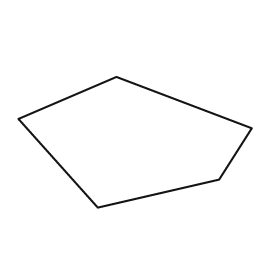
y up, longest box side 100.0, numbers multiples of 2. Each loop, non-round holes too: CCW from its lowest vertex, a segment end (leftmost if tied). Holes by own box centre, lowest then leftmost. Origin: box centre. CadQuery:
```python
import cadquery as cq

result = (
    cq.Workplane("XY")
    .moveTo(-16.0, -28.0)
    .lineTo(36.0, -16.0)
    .lineTo(50.0, 6.0)
    .lineTo(-8.0, 28.0)
    .lineTo(-50.0, 10.0)
    .close()
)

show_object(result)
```